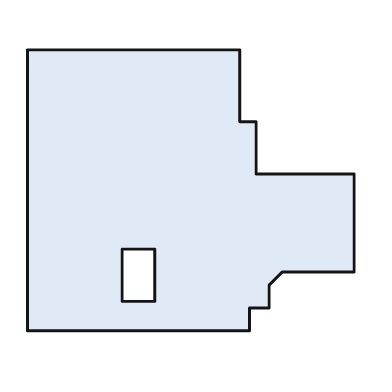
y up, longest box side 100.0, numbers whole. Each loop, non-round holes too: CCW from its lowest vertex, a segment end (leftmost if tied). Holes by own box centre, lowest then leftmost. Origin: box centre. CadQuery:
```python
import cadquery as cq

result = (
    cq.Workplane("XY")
    .moveTo(-50.0, -43.0)
    .lineTo(18.0, -43.0)
    .lineTo(18.0, -36.0)
    .lineTo(24.0, -36.0)
    .lineTo(24.0, -29.0)
    .lineTo(28.0, -25.0)
    .lineTo(50.0, -25.0)
    .lineTo(50.0, 5.0)
    .lineTo(20.0, 5.0)
    .lineTo(20.0, 21.0)
    .lineTo(15.0, 21.0)
    .lineTo(15.0, 43.0)
    .lineTo(-50.0, 43.0)
    .close()
    .moveTo(-21.0, -34.0)
    .lineTo(-11.0, -34.0)
    .lineTo(-11.0, -18.0)
    .lineTo(-21.0, -18.0)
    .close()
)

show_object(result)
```